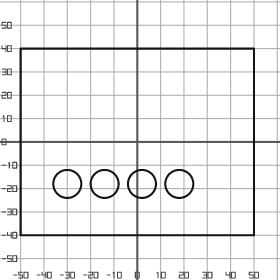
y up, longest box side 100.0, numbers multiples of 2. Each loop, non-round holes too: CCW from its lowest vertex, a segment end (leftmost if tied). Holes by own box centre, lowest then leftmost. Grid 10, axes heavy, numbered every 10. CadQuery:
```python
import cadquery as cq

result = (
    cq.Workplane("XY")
    .moveTo(-50.0, -40.0)
    .lineTo(50.0, -40.0)
    .lineTo(50.0, 40.0)
    .lineTo(-50.0, 40.0)
    .close()
    .moveTo(-30.0, -18.0)
    .circle(6.0)
    .moveTo(-14.0, -18.0)
    .circle(6.0)
    .moveTo(2.0, -18.0)
    .circle(6.0)
    .moveTo(18.0, -18.0)
    .circle(6.0)
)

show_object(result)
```